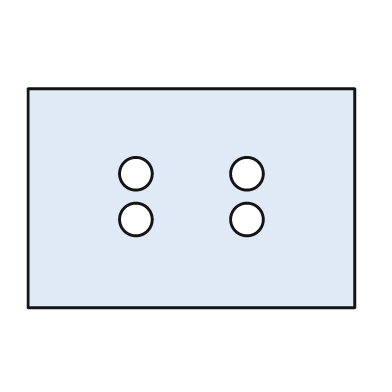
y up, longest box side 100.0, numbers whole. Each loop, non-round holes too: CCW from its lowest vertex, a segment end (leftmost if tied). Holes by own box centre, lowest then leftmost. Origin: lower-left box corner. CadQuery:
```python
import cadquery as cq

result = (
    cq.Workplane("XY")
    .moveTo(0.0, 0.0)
    .lineTo(100.0, 0.0)
    .lineTo(100.0, 67.0)
    .lineTo(0.0, 67.0)
    .close()
    .moveTo(33.0, 27.0)
    .circle(5.0)
    .moveTo(67.0, 27.0)
    .circle(5.0)
    .moveTo(33.0, 41.0)
    .circle(5.0)
    .moveTo(67.0, 41.0)
    .circle(5.0)
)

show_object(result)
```